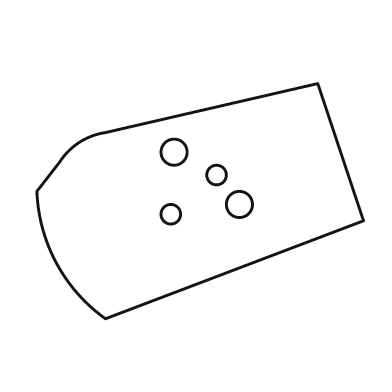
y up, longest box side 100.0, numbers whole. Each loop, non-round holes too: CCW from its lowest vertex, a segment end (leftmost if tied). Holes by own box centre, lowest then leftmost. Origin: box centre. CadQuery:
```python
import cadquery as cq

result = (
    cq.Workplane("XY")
    .moveTo(-29.0, -36.0)
    .lineTo(50.0, -6.0)
    .lineTo(36.0, 36.0)
    .lineTo(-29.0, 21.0)
    .threePointArc((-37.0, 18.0), (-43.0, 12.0))
    .lineTo(-50.0, 3.0)
    .threePointArc((-44.0, -19.0), (-29.0, -36.0))
    .close()
    .moveTo(-9.0, -4.0)
    .circle(3.0)
    .moveTo(12.0, -1.0)
    .circle(4.0)
    .moveTo(5.0, 8.0)
    .circle(3.0)
    .moveTo(-8.0, 15.0)
    .circle(4.0)
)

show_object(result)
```